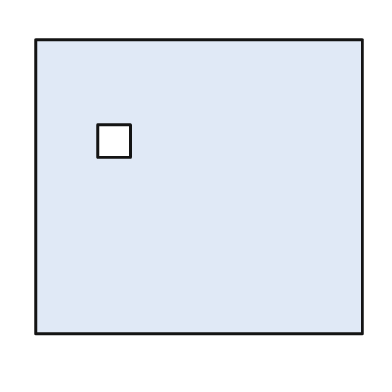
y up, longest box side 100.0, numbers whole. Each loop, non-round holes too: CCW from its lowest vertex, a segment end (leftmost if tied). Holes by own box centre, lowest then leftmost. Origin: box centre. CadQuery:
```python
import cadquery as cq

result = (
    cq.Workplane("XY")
    .moveTo(-50.0, -45.0)
    .lineTo(50.0, -45.0)
    .lineTo(50.0, 45.0)
    .lineTo(-50.0, 45.0)
    .close()
    .moveTo(-31.0, 9.0)
    .lineTo(-21.0, 9.0)
    .lineTo(-21.0, 19.0)
    .lineTo(-31.0, 19.0)
    .close()
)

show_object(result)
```